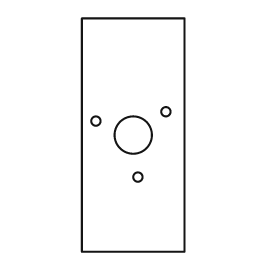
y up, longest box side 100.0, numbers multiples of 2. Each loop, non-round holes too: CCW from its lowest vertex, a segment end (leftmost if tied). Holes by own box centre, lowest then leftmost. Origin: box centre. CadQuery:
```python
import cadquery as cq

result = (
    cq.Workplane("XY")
    .moveTo(-22.0, -50.0)
    .lineTo(22.0, -50.0)
    .lineTo(22.0, 50.0)
    .lineTo(-22.0, 50.0)
    .close()
    .moveTo(2.0, -18.0)
    .circle(2.0)
    .moveTo(0.0, 0.0)
    .circle(8.0)
    .moveTo(-16.0, 6.0)
    .circle(2.0)
    .moveTo(14.0, 10.0)
    .circle(2.0)
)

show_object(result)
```